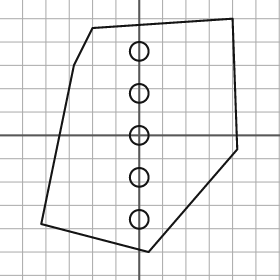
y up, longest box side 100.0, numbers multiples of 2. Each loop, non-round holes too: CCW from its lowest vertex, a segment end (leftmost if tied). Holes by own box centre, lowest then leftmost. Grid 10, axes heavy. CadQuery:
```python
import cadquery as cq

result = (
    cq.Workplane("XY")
    .moveTo(4.0, -50.0)
    .lineTo(42.0, -6.0)
    .lineTo(40.0, 50.0)
    .lineTo(-20.0, 46.0)
    .lineTo(-28.0, 30.0)
    .lineTo(-42.0, -38.0)
    .close()
    .moveTo(0.0, -36.0)
    .circle(4.0)
    .moveTo(0.0, -18.0)
    .circle(4.0)
    .moveTo(0.0, 0.0)
    .circle(4.0)
    .moveTo(0.0, 18.0)
    .circle(4.0)
    .moveTo(0.0, 36.0)
    .circle(4.0)
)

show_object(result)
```